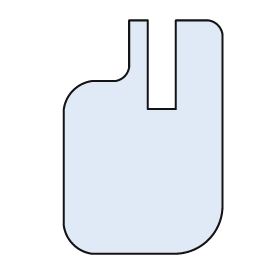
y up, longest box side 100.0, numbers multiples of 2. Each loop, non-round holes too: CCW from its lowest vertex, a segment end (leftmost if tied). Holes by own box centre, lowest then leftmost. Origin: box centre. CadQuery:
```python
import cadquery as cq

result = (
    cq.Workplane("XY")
    .moveTo(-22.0, -50.0)
    .lineTo(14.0, -50.0)
    .threePointArc((28.0, -44.0), (34.0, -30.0))
    .lineTo(34.0, 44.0)
    .threePointArc((32.0, 48.0), (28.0, 50.0))
    .lineTo(14.0, 50.0)
    .lineTo(14.0, 12.0)
    .lineTo(2.0, 12.0)
    .lineTo(2.0, 50.0)
    .lineTo(-6.0, 50.0)
    .lineTo(-6.0, 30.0)
    .threePointArc((-8.0, 26.0), (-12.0, 24.0))
    .lineTo(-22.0, 24.0)
    .threePointArc((-30.0, 20.0), (-34.0, 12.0))
    .lineTo(-34.0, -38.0)
    .threePointArc((-30.0, -46.0), (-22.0, -50.0))
    .close()
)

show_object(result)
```